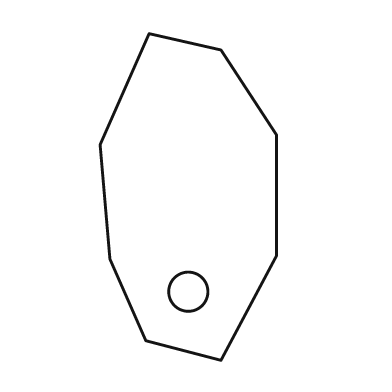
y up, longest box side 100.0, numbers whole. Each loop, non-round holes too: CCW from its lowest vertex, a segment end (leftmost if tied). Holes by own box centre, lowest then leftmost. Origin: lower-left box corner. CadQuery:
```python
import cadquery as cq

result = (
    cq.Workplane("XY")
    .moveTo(37.0, 0.0)
    .lineTo(54.0, 32.0)
    .lineTo(54.0, 69.0)
    .lineTo(37.0, 95.0)
    .lineTo(15.0, 100.0)
    .lineTo(0.0, 66.0)
    .lineTo(3.0, 31.0)
    .lineTo(14.0, 6.0)
    .close()
    .moveTo(27.0, 21.0)
    .circle(6.0)
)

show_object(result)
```